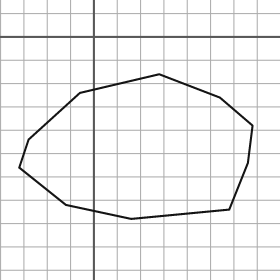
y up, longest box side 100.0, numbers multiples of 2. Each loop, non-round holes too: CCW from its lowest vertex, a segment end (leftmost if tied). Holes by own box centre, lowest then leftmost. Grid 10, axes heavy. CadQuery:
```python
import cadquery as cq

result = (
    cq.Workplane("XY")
    .moveTo(16.0, -78.0)
    .lineTo(58.0, -74.0)
    .lineTo(66.0, -54.0)
    .lineTo(68.0, -38.0)
    .lineTo(54.0, -26.0)
    .lineTo(28.0, -16.0)
    .lineTo(-6.0, -24.0)
    .lineTo(-28.0, -44.0)
    .lineTo(-32.0, -56.0)
    .lineTo(-12.0, -72.0)
    .close()
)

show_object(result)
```